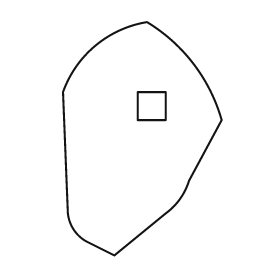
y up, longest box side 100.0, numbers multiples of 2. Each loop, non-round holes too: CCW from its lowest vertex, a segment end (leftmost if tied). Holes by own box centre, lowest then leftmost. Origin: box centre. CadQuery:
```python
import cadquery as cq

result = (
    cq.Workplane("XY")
    .moveTo(-12.0, -50.0)
    .lineTo(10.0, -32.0)
    .threePointArc((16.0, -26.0), (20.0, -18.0))
    .lineTo(34.0, 8.0)
    .threePointArc((22.0, 32.0), (2.0, 50.0))
    .threePointArc((-20.0, 40.0), (-34.0, 20.0))
    .lineTo(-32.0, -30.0)
    .threePointArc((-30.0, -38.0), (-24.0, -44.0))
    .close()
    .moveTo(-2.0, 8.0)
    .lineTo(10.0, 8.0)
    .lineTo(10.0, 20.0)
    .lineTo(-2.0, 20.0)
    .close()
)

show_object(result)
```